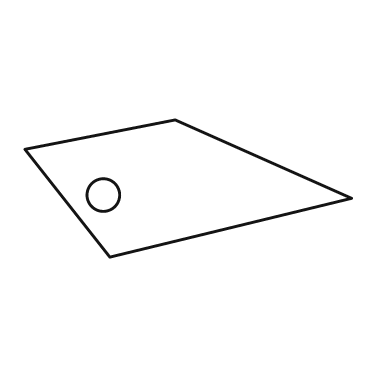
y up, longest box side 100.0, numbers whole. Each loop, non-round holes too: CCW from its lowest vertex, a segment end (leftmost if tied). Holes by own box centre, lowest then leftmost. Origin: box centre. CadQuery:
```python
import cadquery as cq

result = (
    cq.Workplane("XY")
    .moveTo(-24.0, -21.0)
    .lineTo(50.0, -3.0)
    .lineTo(-4.0, 21.0)
    .lineTo(-50.0, 12.0)
    .close()
    .moveTo(-26.0, -2.0)
    .circle(5.0)
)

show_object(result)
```